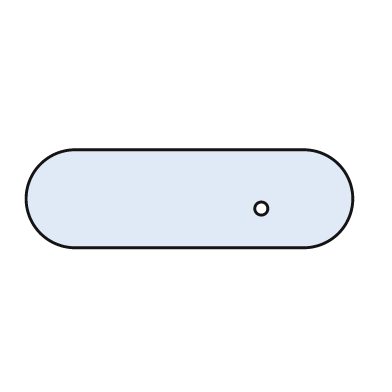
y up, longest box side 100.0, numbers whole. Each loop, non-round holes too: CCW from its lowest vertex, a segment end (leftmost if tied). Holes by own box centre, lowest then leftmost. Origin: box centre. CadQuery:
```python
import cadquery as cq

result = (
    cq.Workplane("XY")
    .moveTo(-35.0, -15.0)
    .lineTo(35.0, -15.0)
    .threePointArc((50.0, 0.0), (35.0, 15.0))
    .lineTo(-35.0, 15.0)
    .threePointArc((-50.0, 0.0), (-35.0, -15.0))
    .close()
    .moveTo(22.0, -3.0)
    .circle(2.0)
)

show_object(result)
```